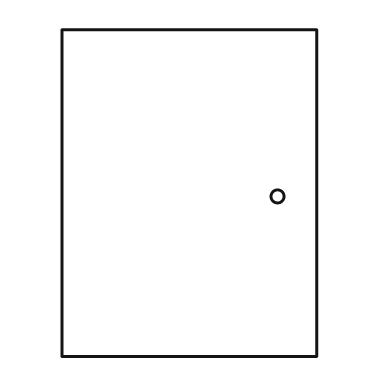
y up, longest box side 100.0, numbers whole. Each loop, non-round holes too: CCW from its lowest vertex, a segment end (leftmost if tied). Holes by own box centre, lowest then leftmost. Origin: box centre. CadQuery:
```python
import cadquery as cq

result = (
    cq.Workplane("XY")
    .moveTo(-39.0, -50.0)
    .lineTo(39.0, -50.0)
    .lineTo(39.0, 50.0)
    .lineTo(-39.0, 50.0)
    .close()
    .moveTo(27.0, -1.0)
    .circle(2.0)
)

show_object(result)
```